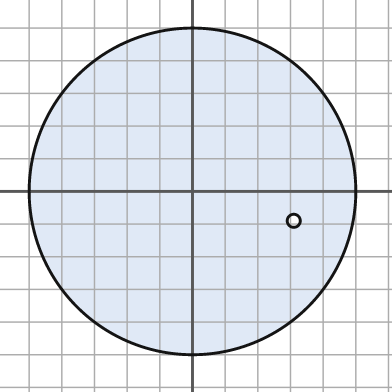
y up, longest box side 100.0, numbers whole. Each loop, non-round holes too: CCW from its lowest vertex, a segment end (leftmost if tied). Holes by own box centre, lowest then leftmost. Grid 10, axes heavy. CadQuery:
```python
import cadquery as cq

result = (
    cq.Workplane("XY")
    .moveTo(0.0, 0.0)
    .circle(50.0)
    .moveTo(31.0, -9.0)
    .circle(2.0)
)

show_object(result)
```